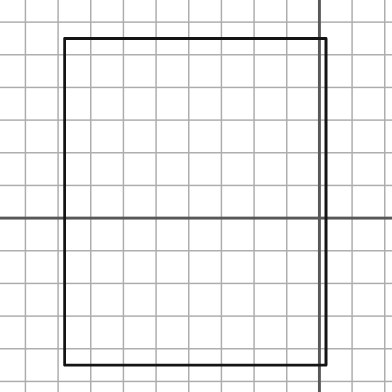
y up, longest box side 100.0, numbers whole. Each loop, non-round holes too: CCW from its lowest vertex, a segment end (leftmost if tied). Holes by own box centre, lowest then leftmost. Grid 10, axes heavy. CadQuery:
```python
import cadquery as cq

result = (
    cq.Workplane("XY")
    .moveTo(-78.0, -45.0)
    .lineTo(2.0, -45.0)
    .lineTo(2.0, 55.0)
    .lineTo(-78.0, 55.0)
    .close()
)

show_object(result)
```